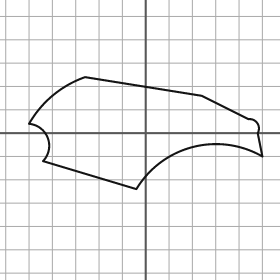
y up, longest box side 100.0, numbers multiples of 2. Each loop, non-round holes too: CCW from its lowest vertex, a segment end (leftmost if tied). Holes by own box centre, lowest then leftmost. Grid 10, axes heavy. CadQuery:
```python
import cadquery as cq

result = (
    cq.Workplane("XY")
    .moveTo(-4.0, -24.0)
    .threePointArc((20.0, -6.0), (50.0, -10.0))
    .lineTo(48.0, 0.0)
    .threePointArc((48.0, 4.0), (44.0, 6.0))
    .lineTo(24.0, 16.0)
    .lineTo(-26.0, 24.0)
    .threePointArc((-40.0, 16.0), (-50.0, 4.0))
    .threePointArc((-42.0, -2.0), (-44.0, -12.0))
    .close()
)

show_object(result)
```